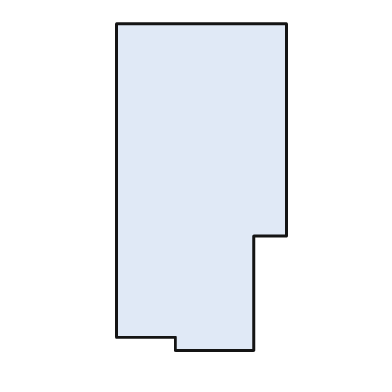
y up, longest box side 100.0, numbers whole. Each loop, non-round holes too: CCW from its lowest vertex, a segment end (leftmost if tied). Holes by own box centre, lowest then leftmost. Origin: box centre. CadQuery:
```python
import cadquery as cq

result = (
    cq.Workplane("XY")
    .moveTo(-8.0, -50.0)
    .lineTo(16.0, -50.0)
    .lineTo(16.0, -15.0)
    .lineTo(26.0, -15.0)
    .lineTo(26.0, 50.0)
    .lineTo(-26.0, 50.0)
    .lineTo(-26.0, -46.0)
    .lineTo(-8.0, -46.0)
    .close()
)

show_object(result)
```